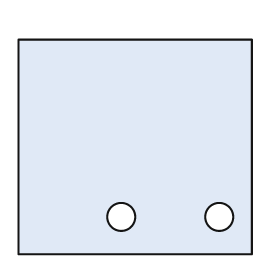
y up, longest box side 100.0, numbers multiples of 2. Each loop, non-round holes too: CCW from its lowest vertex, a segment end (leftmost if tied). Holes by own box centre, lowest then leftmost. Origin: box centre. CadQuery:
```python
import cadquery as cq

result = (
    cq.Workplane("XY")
    .moveTo(-50.0, -46.0)
    .lineTo(50.0, -46.0)
    .lineTo(50.0, 46.0)
    .lineTo(-50.0, 46.0)
    .close()
    .moveTo(-6.0, -30.0)
    .circle(6.0)
    .moveTo(36.0, -30.0)
    .circle(6.0)
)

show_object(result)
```